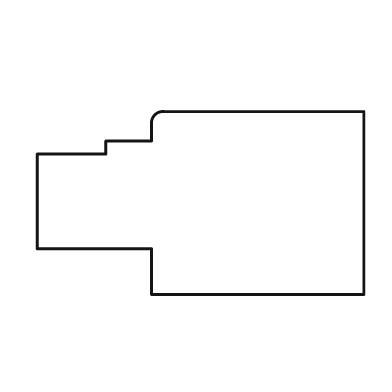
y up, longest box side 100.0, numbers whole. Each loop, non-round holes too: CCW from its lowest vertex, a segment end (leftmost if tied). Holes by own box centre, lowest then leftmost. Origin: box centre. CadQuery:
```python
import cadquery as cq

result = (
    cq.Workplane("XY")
    .moveTo(-15.0, -28.0)
    .lineTo(50.0, -28.0)
    .lineTo(50.0, 28.0)
    .lineTo(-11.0, 28.0)
    .threePointArc((-14.0, 27.0), (-15.0, 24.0))
    .lineTo(-15.0, 19.0)
    .lineTo(-29.0, 19.0)
    .lineTo(-29.0, 15.0)
    .lineTo(-50.0, 15.0)
    .lineTo(-50.0, -14.0)
    .lineTo(-15.0, -14.0)
    .close()
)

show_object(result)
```